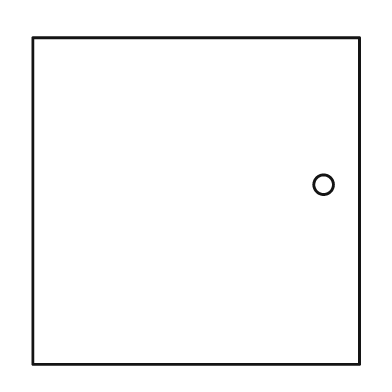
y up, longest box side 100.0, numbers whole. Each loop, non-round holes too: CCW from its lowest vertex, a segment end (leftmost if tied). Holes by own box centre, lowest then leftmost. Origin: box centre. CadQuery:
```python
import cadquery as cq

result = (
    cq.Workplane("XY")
    .moveTo(-50.0, -50.0)
    .lineTo(50.0, -50.0)
    .lineTo(50.0, 50.0)
    .lineTo(-50.0, 50.0)
    .close()
    .moveTo(39.0, 5.0)
    .circle(3.0)
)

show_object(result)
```